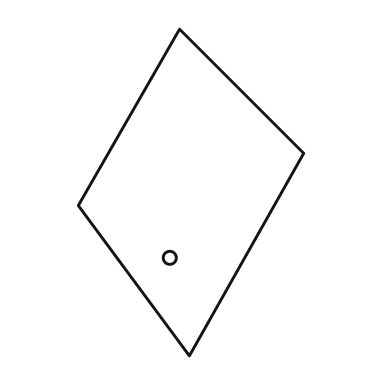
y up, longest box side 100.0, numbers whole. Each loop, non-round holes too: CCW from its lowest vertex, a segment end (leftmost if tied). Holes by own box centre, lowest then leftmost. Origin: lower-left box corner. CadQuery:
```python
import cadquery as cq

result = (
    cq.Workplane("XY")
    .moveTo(34.0, 0.0)
    .lineTo(69.0, 62.0)
    .lineTo(31.0, 100.0)
    .lineTo(0.0, 46.0)
    .close()
    .moveTo(28.0, 30.0)
    .circle(2.0)
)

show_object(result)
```